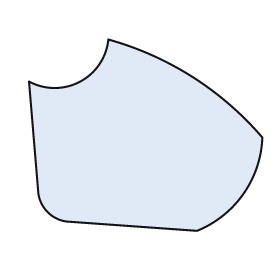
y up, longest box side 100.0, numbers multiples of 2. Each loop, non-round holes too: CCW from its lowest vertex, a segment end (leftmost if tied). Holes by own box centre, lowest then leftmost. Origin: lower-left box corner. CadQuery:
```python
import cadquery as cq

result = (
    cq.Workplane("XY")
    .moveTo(72.0, 0.0)
    .threePointArc((92.0, 16.0), (100.0, 40.0))
    .threePointArc((70.0, 66.0), (34.0, 82.0))
    .threePointArc((22.0, 64.0), (0.0, 64.0))
    .lineTo(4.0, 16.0)
    .threePointArc((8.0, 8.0), (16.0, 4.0))
    .close()
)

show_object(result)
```